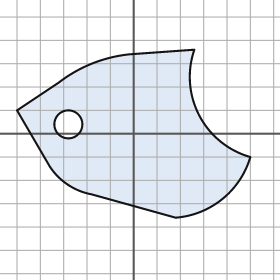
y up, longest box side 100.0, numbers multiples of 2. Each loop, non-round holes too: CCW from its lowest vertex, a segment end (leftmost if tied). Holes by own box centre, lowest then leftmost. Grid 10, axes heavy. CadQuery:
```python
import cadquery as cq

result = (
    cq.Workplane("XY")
    .moveTo(18.0, -36.0)
    .threePointArc((38.0, -28.0), (50.0, -10.0))
    .threePointArc((28.0, 8.0), (26.0, 36.0))
    .lineTo(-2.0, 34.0)
    .threePointArc((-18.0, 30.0), (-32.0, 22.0))
    .lineTo(-50.0, 10.0)
    .lineTo(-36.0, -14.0)
    .threePointArc((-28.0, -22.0), (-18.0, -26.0))
    .close()
    .moveTo(-28.0, 4.0)
    .circle(6.0)
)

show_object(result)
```